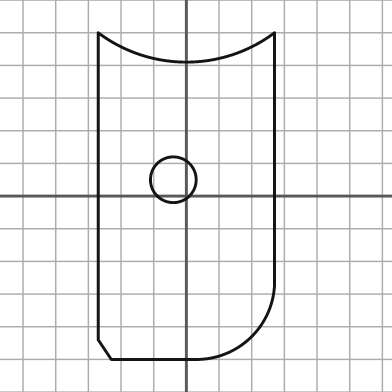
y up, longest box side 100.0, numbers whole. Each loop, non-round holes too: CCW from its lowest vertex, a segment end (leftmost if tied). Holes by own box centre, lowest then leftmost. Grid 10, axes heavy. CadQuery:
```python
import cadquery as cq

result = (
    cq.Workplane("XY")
    .moveTo(-23.0, -50.0)
    .lineTo(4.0, -50.0)
    .threePointArc((20.0, -43.0), (27.0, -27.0))
    .lineTo(27.0, 50.0)
    .threePointArc((0.0, 41.0), (-27.0, 50.0))
    .lineTo(-27.0, -44.0)
    .close()
    .moveTo(-4.0, 5.0)
    .circle(7.0)
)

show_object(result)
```